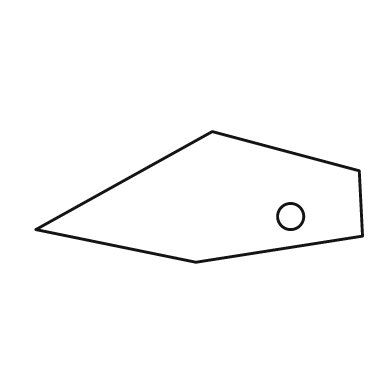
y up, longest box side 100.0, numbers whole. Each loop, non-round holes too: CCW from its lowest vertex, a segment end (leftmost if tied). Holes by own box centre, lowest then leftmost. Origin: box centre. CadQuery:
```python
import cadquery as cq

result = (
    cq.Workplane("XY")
    .moveTo(-1.0, -20.0)
    .lineTo(50.0, -12.0)
    .lineTo(49.0, 8.0)
    .lineTo(4.0, 20.0)
    .lineTo(-50.0, -10.0)
    .close()
    .moveTo(28.0, -6.0)
    .circle(4.0)
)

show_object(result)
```